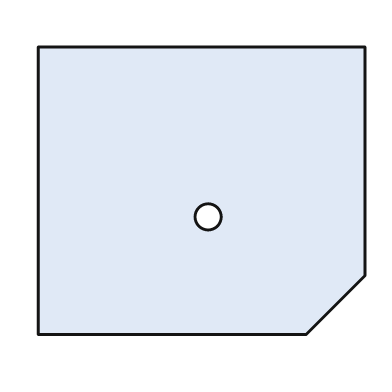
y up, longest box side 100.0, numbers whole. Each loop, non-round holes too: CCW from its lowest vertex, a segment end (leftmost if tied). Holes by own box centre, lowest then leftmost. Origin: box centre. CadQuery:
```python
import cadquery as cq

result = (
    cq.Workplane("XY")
    .moveTo(-50.0, -44.0)
    .lineTo(32.0, -44.0)
    .lineTo(50.0, -26.0)
    .lineTo(50.0, 44.0)
    .lineTo(-50.0, 44.0)
    .close()
    .moveTo(2.0, -8.0)
    .circle(4.0)
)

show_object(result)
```